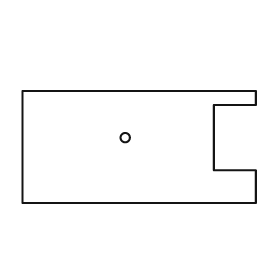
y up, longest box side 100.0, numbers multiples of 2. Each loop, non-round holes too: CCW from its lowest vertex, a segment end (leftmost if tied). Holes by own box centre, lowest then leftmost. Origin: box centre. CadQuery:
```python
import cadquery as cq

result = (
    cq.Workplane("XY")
    .moveTo(-50.0, -24.0)
    .lineTo(50.0, -24.0)
    .lineTo(50.0, -10.0)
    .lineTo(32.0, -10.0)
    .lineTo(32.0, 18.0)
    .lineTo(50.0, 18.0)
    .lineTo(50.0, 24.0)
    .lineTo(-50.0, 24.0)
    .close()
    .moveTo(-6.0, 4.0)
    .circle(2.0)
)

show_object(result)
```